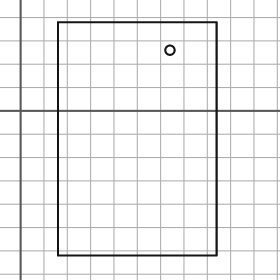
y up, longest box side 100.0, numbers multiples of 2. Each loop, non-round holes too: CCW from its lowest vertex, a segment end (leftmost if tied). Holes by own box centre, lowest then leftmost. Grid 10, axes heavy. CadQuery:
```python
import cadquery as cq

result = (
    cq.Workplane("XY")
    .moveTo(16.0, -62.0)
    .lineTo(84.0, -62.0)
    .lineTo(84.0, 38.0)
    .lineTo(16.0, 38.0)
    .close()
    .moveTo(64.0, 26.0)
    .circle(2.0)
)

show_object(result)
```